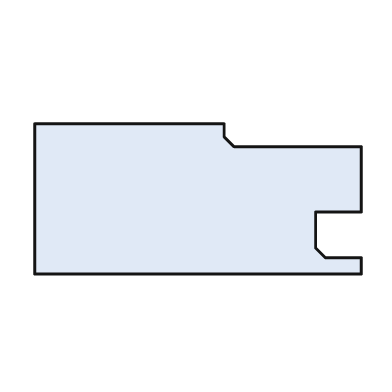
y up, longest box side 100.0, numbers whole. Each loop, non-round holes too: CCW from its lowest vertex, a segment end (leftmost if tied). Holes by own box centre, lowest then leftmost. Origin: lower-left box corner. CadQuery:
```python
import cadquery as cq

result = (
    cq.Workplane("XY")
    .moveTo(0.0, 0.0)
    .lineTo(100.0, 0.0)
    .lineTo(100.0, 5.0)
    .lineTo(89.0, 5.0)
    .lineTo(86.0, 8.0)
    .lineTo(86.0, 19.0)
    .lineTo(100.0, 19.0)
    .lineTo(100.0, 39.0)
    .lineTo(61.0, 39.0)
    .lineTo(58.0, 42.0)
    .lineTo(58.0, 46.0)
    .lineTo(0.0, 46.0)
    .close()
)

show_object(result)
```